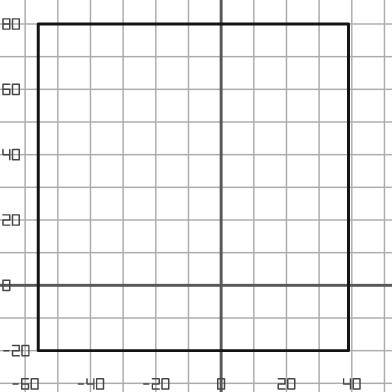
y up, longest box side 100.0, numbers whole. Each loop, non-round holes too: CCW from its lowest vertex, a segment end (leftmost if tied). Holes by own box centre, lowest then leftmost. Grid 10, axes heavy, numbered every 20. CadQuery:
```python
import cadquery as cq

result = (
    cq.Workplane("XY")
    .moveTo(-56.0, -20.0)
    .lineTo(39.0, -20.0)
    .lineTo(39.0, 80.0)
    .lineTo(-56.0, 80.0)
    .close()
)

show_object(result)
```